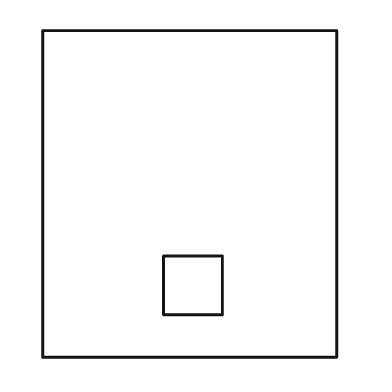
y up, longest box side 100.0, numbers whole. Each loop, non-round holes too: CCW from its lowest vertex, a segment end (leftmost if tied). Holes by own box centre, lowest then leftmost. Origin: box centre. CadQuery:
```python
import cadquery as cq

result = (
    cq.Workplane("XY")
    .moveTo(-45.0, -50.0)
    .lineTo(45.0, -50.0)
    .lineTo(45.0, 50.0)
    .lineTo(-45.0, 50.0)
    .close()
    .moveTo(-8.0, -37.0)
    .lineTo(10.0, -37.0)
    .lineTo(10.0, -19.0)
    .lineTo(-8.0, -19.0)
    .close()
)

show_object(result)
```